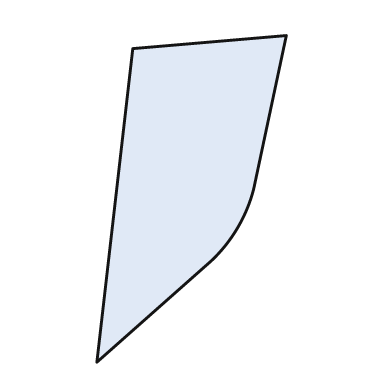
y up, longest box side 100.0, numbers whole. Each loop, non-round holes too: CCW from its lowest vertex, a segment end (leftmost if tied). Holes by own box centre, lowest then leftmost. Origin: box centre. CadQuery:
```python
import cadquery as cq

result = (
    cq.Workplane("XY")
    .moveTo(-29.0, -50.0)
    .lineTo(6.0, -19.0)
    .threePointArc((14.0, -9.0), (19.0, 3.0))
    .lineTo(29.0, 50.0)
    .lineTo(-18.0, 46.0)
    .close()
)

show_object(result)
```